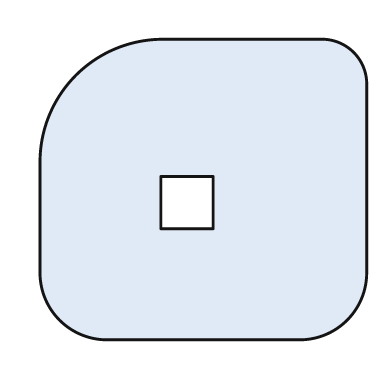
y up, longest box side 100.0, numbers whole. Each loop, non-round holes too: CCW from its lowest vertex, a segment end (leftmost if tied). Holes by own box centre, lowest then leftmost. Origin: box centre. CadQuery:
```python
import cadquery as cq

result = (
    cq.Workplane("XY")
    .moveTo(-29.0, -46.0)
    .lineTo(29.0, -46.0)
    .threePointArc((44.0, -40.0), (50.0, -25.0))
    .lineTo(50.0, 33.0)
    .threePointArc((46.0, 42.0), (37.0, 46.0))
    .lineTo(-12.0, 46.0)
    .threePointArc((-39.0, 35.0), (-50.0, 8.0))
    .lineTo(-50.0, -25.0)
    .threePointArc((-44.0, -40.0), (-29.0, -46.0))
    .close()
    .moveTo(-13.0, -12.0)
    .lineTo(3.0, -12.0)
    .lineTo(3.0, 4.0)
    .lineTo(-13.0, 4.0)
    .close()
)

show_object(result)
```